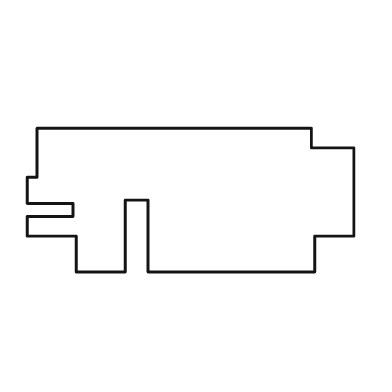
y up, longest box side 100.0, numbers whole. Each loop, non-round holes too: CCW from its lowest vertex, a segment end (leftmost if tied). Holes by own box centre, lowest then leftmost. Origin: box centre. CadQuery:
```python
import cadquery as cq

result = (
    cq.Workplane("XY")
    .moveTo(-35.0, -22.0)
    .lineTo(-20.0, -22.0)
    .lineTo(-20.0, 0.0)
    .lineTo(-13.0, 0.0)
    .lineTo(-13.0, -22.0)
    .lineTo(38.0, -22.0)
    .lineTo(38.0, -11.0)
    .lineTo(50.0, -11.0)
    .lineTo(50.0, 16.0)
    .lineTo(37.0, 16.0)
    .lineTo(37.0, 22.0)
    .lineTo(-47.0, 22.0)
    .lineTo(-47.0, 7.0)
    .lineTo(-50.0, 7.0)
    .lineTo(-50.0, -1.0)
    .lineTo(-36.0, -1.0)
    .lineTo(-36.0, -5.0)
    .lineTo(-50.0, -5.0)
    .lineTo(-50.0, -11.0)
    .lineTo(-35.0, -11.0)
    .close()
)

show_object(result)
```